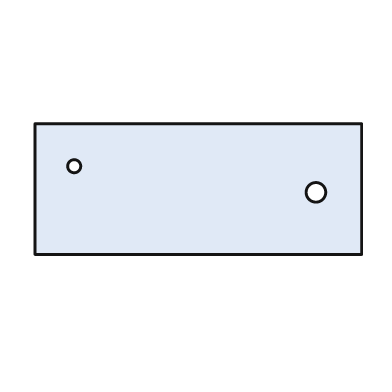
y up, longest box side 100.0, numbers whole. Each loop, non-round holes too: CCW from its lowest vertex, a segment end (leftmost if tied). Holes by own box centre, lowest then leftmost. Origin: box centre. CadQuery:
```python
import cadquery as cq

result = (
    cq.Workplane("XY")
    .moveTo(-50.0, -20.0)
    .lineTo(50.0, -20.0)
    .lineTo(50.0, 20.0)
    .lineTo(-50.0, 20.0)
    .close()
    .moveTo(36.0, -1.0)
    .circle(3.0)
    .moveTo(-38.0, 7.0)
    .circle(2.0)
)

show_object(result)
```